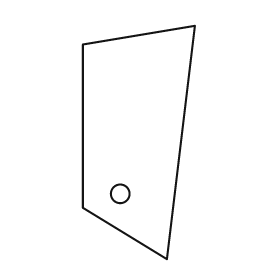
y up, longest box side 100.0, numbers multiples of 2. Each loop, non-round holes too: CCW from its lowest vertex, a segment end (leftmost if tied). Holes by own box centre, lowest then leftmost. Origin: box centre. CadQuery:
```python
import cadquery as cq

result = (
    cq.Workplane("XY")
    .moveTo(12.0, -50.0)
    .lineTo(24.0, 50.0)
    .lineTo(-24.0, 42.0)
    .lineTo(-24.0, -28.0)
    .close()
    .moveTo(-8.0, -22.0)
    .circle(4.0)
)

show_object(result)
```